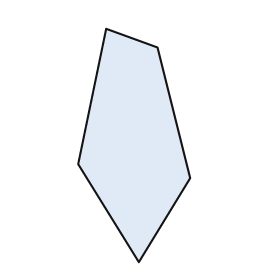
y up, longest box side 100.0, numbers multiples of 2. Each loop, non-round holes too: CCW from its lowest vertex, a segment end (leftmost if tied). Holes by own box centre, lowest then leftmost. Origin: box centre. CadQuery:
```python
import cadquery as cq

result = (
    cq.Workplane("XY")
    .moveTo(2.0, -50.0)
    .lineTo(24.0, -14.0)
    .lineTo(10.0, 42.0)
    .lineTo(-12.0, 50.0)
    .lineTo(-24.0, -8.0)
    .close()
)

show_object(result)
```